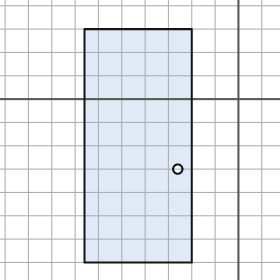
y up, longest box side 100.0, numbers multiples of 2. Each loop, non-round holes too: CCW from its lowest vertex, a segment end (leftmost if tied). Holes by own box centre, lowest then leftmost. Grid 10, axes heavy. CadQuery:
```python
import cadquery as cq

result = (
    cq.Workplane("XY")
    .moveTo(-66.0, -70.0)
    .lineTo(-20.0, -70.0)
    .lineTo(-20.0, 30.0)
    .lineTo(-66.0, 30.0)
    .close()
    .moveTo(-26.0, -30.0)
    .circle(2.0)
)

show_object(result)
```